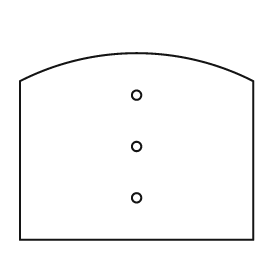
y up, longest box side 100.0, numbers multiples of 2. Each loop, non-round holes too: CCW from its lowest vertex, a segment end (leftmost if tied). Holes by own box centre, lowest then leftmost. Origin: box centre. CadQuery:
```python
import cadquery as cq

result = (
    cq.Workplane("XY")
    .moveTo(-50.0, -40.0)
    .lineTo(50.0, -40.0)
    .lineTo(50.0, 28.0)
    .threePointArc((0.0, 40.0), (-50.0, 28.0))
    .close()
    .moveTo(0.0, -22.0)
    .circle(2.0)
    .moveTo(0.0, 0.0)
    .circle(2.0)
    .moveTo(0.0, 22.0)
    .circle(2.0)
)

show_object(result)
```